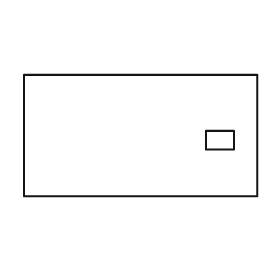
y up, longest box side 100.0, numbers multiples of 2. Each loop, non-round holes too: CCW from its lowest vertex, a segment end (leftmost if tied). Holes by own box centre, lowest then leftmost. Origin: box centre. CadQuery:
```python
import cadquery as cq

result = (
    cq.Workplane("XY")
    .moveTo(-50.0, -26.0)
    .lineTo(50.0, -26.0)
    .lineTo(50.0, 26.0)
    .lineTo(-50.0, 26.0)
    .close()
    .moveTo(28.0, -6.0)
    .lineTo(40.0, -6.0)
    .lineTo(40.0, 2.0)
    .lineTo(28.0, 2.0)
    .close()
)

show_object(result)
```